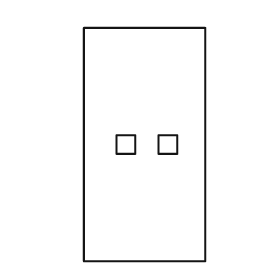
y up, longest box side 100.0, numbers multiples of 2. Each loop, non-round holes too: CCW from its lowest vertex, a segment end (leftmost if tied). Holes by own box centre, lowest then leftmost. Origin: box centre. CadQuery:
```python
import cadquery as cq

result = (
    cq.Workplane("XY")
    .moveTo(-26.0, -50.0)
    .lineTo(26.0, -50.0)
    .lineTo(26.0, 50.0)
    .lineTo(-26.0, 50.0)
    .close()
    .moveTo(-12.0, -4.0)
    .lineTo(-4.0, -4.0)
    .lineTo(-4.0, 4.0)
    .lineTo(-12.0, 4.0)
    .close()
    .moveTo(6.0, -4.0)
    .lineTo(14.0, -4.0)
    .lineTo(14.0, 4.0)
    .lineTo(6.0, 4.0)
    .close()
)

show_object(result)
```